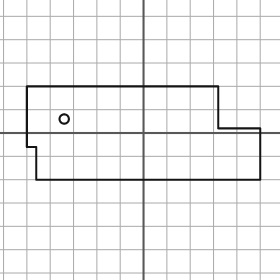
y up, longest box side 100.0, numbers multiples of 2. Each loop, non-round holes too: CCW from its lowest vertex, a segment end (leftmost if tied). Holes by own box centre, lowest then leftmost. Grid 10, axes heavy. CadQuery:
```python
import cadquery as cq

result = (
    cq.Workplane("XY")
    .moveTo(-46.0, -20.0)
    .lineTo(50.0, -20.0)
    .lineTo(50.0, 2.0)
    .lineTo(32.0, 2.0)
    .lineTo(32.0, 20.0)
    .lineTo(-50.0, 20.0)
    .lineTo(-50.0, -6.0)
    .lineTo(-46.0, -6.0)
    .close()
    .moveTo(-34.0, 6.0)
    .circle(2.0)
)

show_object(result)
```